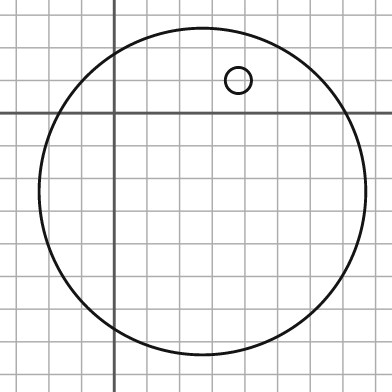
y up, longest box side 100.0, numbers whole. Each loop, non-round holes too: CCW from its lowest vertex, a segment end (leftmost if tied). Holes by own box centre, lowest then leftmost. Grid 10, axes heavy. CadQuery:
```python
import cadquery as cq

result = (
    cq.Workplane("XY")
    .moveTo(27.0, -24.0)
    .circle(50.0)
    .moveTo(38.0, 10.0)
    .circle(4.0)
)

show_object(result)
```